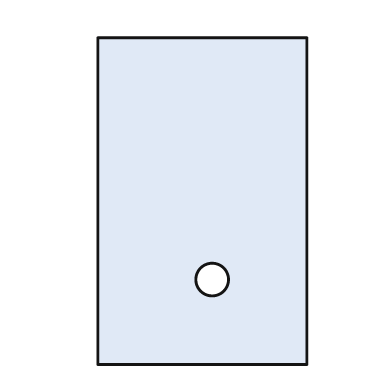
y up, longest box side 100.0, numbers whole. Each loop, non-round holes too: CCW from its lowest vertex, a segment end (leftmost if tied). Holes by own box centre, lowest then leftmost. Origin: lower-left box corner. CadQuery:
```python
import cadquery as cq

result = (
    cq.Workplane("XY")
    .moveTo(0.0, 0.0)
    .lineTo(64.0, 0.0)
    .lineTo(64.0, 100.0)
    .lineTo(0.0, 100.0)
    .close()
    .moveTo(35.0, 26.0)
    .circle(5.0)
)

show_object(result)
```